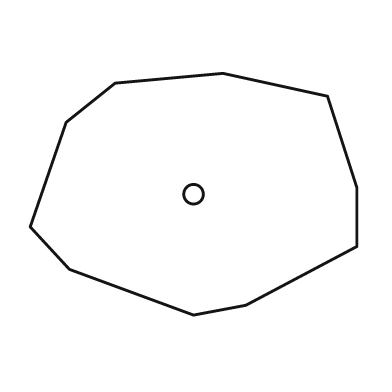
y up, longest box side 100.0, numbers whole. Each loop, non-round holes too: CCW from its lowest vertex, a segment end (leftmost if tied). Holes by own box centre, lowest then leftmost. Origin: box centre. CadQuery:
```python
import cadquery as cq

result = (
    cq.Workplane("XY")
    .moveTo(0.0, -37.0)
    .lineTo(16.0, -34.0)
    .lineTo(50.0, -16.0)
    .lineTo(50.0, 2.0)
    .lineTo(41.0, 30.0)
    .lineTo(9.0, 37.0)
    .lineTo(-24.0, 34.0)
    .lineTo(-39.0, 22.0)
    .lineTo(-50.0, -10.0)
    .lineTo(-38.0, -23.0)
    .close()
    .moveTo(0.0, 0.0)
    .circle(3.0)
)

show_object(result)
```